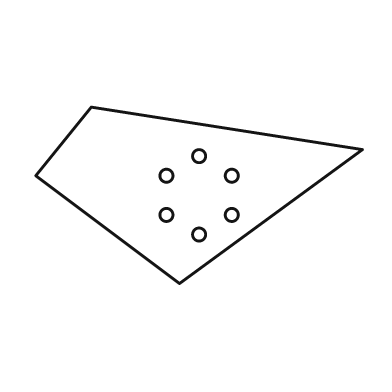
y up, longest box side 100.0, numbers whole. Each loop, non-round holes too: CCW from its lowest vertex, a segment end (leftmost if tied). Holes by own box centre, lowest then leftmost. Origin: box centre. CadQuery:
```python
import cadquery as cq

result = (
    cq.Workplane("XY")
    .moveTo(-6.0, -27.0)
    .lineTo(50.0, 14.0)
    .lineTo(-33.0, 27.0)
    .lineTo(-50.0, 6.0)
    .close()
    .moveTo(0.0, -12.0)
    .circle(2.0)
    .moveTo(-10.0, -6.0)
    .circle(2.0)
    .moveTo(10.0, -6.0)
    .circle(2.0)
    .moveTo(-10.0, 6.0)
    .circle(2.0)
    .moveTo(10.0, 6.0)
    .circle(2.0)
    .moveTo(0.0, 12.0)
    .circle(2.0)
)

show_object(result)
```